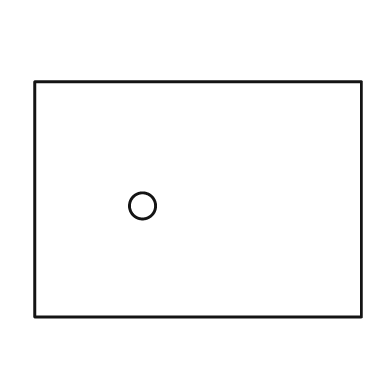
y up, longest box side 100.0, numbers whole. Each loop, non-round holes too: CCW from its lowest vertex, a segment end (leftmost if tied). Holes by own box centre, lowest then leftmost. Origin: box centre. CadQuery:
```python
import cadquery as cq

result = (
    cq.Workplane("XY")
    .moveTo(-50.0, -36.0)
    .lineTo(50.0, -36.0)
    .lineTo(50.0, 36.0)
    .lineTo(-50.0, 36.0)
    .close()
    .moveTo(-17.0, -2.0)
    .circle(4.0)
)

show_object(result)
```